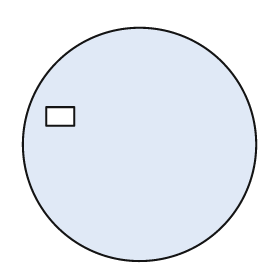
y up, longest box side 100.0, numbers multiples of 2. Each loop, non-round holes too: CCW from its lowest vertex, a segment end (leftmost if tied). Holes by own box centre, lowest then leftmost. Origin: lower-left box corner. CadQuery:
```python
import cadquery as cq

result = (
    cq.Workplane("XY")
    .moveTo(50.0, 50.0)
    .circle(50.0)
    .moveTo(10.0, 58.0)
    .lineTo(22.0, 58.0)
    .lineTo(22.0, 66.0)
    .lineTo(10.0, 66.0)
    .close()
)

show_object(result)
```